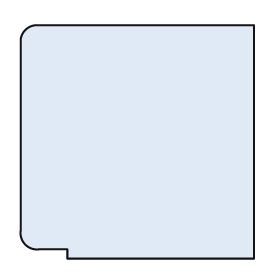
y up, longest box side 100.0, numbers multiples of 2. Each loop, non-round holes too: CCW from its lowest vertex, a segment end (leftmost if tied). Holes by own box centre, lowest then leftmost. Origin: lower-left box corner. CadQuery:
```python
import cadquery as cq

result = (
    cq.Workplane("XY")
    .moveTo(20.0, 0.0)
    .lineTo(100.0, 0.0)
    .lineTo(100.0, 100.0)
    .lineTo(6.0, 100.0)
    .threePointArc((2.0, 98.0), (0.0, 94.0))
    .lineTo(0.0, 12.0)
    .threePointArc((2.0, 6.0), (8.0, 4.0))
    .lineTo(20.0, 4.0)
    .close()
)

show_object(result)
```